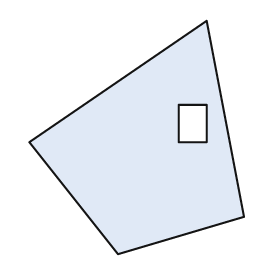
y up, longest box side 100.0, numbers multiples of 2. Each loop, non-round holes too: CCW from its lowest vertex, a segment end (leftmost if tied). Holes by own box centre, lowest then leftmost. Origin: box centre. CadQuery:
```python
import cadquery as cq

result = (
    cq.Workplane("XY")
    .moveTo(-8.0, -50.0)
    .lineTo(46.0, -34.0)
    .lineTo(30.0, 50.0)
    .lineTo(-46.0, -2.0)
    .close()
    .moveTo(18.0, -2.0)
    .lineTo(30.0, -2.0)
    .lineTo(30.0, 14.0)
    .lineTo(18.0, 14.0)
    .close()
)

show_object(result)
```